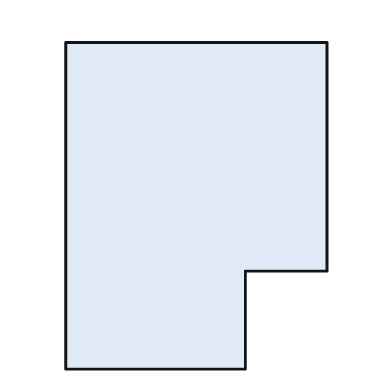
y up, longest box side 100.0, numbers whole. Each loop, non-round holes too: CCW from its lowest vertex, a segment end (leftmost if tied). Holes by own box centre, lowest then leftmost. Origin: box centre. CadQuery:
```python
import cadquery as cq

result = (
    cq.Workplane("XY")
    .moveTo(-40.0, -50.0)
    .lineTo(15.0, -50.0)
    .lineTo(15.0, -20.0)
    .lineTo(40.0, -20.0)
    .lineTo(40.0, 50.0)
    .lineTo(-40.0, 50.0)
    .close()
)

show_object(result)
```